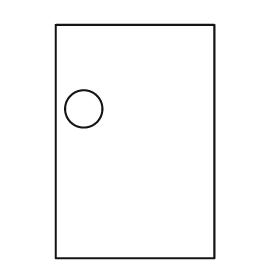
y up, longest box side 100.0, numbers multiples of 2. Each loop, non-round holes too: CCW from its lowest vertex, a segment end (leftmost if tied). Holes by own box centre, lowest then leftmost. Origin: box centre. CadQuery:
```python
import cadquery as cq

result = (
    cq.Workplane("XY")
    .moveTo(-34.0, -50.0)
    .lineTo(34.0, -50.0)
    .lineTo(34.0, 50.0)
    .lineTo(-34.0, 50.0)
    .close()
    .moveTo(-22.0, 14.0)
    .circle(8.0)
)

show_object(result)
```